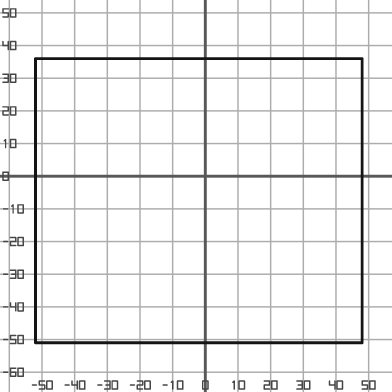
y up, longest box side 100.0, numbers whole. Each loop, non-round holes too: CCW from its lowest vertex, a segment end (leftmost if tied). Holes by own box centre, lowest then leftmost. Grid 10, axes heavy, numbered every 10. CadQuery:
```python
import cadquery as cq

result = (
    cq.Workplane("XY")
    .moveTo(-52.0, -51.0)
    .lineTo(48.0, -51.0)
    .lineTo(48.0, 36.0)
    .lineTo(-52.0, 36.0)
    .close()
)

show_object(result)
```